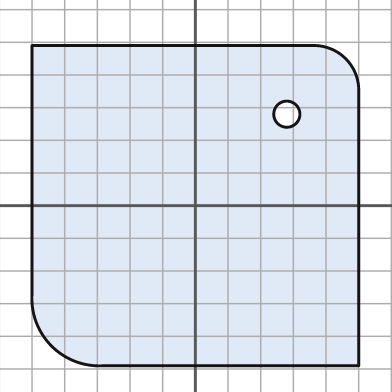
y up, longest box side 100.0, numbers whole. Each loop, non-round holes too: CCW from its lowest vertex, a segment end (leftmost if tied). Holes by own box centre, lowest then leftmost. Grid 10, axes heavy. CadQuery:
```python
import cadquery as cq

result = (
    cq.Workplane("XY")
    .moveTo(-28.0, -49.0)
    .lineTo(50.0, -49.0)
    .lineTo(50.0, 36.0)
    .threePointArc((46.0, 45.0), (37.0, 49.0))
    .lineTo(-50.0, 49.0)
    .lineTo(-50.0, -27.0)
    .threePointArc((-44.0, -43.0), (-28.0, -49.0))
    .close()
    .moveTo(28.0, 28.0)
    .circle(4.0)
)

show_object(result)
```